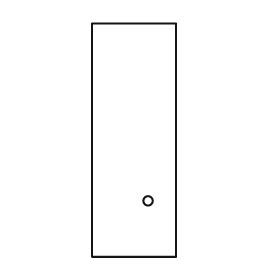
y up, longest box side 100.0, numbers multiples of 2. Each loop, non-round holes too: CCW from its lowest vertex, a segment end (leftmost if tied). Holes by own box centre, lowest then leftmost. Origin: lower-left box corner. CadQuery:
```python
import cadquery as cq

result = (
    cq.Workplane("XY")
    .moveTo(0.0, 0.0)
    .lineTo(36.0, 0.0)
    .lineTo(36.0, 100.0)
    .lineTo(0.0, 100.0)
    .close()
    .moveTo(24.0, 24.0)
    .circle(2.0)
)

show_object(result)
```